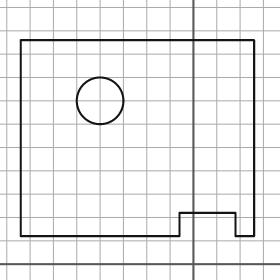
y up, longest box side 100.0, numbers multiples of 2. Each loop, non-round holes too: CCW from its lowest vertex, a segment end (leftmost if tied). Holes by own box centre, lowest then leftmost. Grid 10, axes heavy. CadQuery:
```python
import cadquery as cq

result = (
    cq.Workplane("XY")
    .moveTo(-74.0, 12.0)
    .lineTo(-6.0, 12.0)
    .lineTo(-6.0, 22.0)
    .lineTo(18.0, 22.0)
    .lineTo(18.0, 12.0)
    .lineTo(26.0, 12.0)
    .lineTo(26.0, 96.0)
    .lineTo(-74.0, 96.0)
    .close()
    .moveTo(-40.0, 70.0)
    .circle(10.0)
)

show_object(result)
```